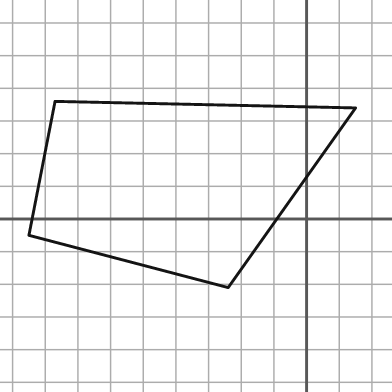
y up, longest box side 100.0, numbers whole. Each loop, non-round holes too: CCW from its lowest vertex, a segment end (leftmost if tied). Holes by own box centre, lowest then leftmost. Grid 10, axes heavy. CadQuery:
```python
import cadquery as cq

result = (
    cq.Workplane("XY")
    .moveTo(-24.0, -21.0)
    .lineTo(15.0, 34.0)
    .lineTo(-77.0, 36.0)
    .lineTo(-85.0, -5.0)
    .close()
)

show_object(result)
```